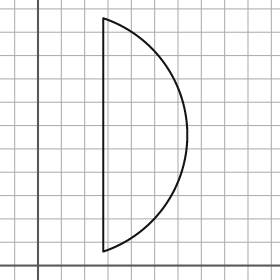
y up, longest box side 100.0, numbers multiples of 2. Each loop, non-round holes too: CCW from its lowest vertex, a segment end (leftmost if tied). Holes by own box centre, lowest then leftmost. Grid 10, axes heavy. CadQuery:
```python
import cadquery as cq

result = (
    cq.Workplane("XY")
    .moveTo(28.0, 6.0)
    .threePointArc((64.0, 56.0), (28.0, 106.0))
    .close()
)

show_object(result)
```